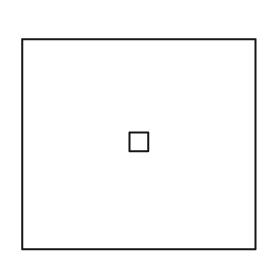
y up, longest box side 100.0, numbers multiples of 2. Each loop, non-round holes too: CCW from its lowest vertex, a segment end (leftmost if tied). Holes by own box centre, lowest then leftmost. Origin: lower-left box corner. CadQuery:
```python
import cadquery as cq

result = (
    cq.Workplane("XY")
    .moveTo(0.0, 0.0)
    .lineTo(100.0, 0.0)
    .lineTo(100.0, 90.0)
    .lineTo(0.0, 90.0)
    .close()
    .moveTo(46.0, 42.0)
    .lineTo(54.0, 42.0)
    .lineTo(54.0, 50.0)
    .lineTo(46.0, 50.0)
    .close()
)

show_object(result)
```